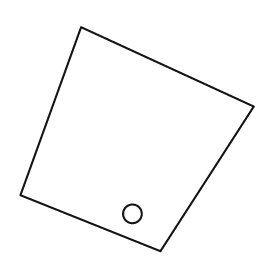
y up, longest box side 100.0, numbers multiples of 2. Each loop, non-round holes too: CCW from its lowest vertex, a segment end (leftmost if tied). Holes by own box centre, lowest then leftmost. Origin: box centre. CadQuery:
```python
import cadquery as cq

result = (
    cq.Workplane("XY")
    .moveTo(10.0, -48.0)
    .lineTo(50.0, 14.0)
    .lineTo(-24.0, 48.0)
    .lineTo(-50.0, -24.0)
    .close()
    .moveTo(-2.0, -32.0)
    .circle(4.0)
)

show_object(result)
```